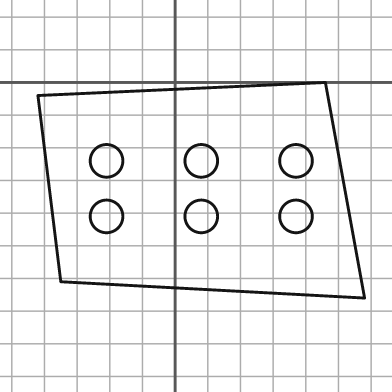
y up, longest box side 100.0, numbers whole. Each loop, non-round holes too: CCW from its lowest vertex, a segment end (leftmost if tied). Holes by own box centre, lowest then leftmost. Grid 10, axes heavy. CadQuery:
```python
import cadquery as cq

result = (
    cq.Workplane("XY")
    .moveTo(58.0, -66.0)
    .lineTo(46.0, 0.0)
    .lineTo(-42.0, -4.0)
    .lineTo(-35.0, -61.0)
    .close()
    .moveTo(-21.0, -41.0)
    .circle(5.0)
    .moveTo(8.0, -41.0)
    .circle(5.0)
    .moveTo(37.0, -41.0)
    .circle(5.0)
    .moveTo(-21.0, -24.0)
    .circle(5.0)
    .moveTo(8.0, -24.0)
    .circle(5.0)
    .moveTo(37.0, -24.0)
    .circle(5.0)
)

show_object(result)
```